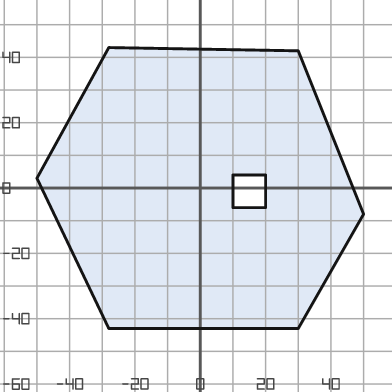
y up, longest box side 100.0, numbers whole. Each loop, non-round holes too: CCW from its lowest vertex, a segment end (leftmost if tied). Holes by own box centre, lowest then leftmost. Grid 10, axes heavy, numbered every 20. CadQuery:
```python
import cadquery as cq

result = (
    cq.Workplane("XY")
    .moveTo(-28.0, -43.0)
    .lineTo(30.0, -43.0)
    .lineTo(50.0, -8.0)
    .lineTo(30.0, 42.0)
    .lineTo(-28.0, 43.0)
    .lineTo(-50.0, 3.0)
    .close()
    .moveTo(10.0, -6.0)
    .lineTo(20.0, -6.0)
    .lineTo(20.0, 4.0)
    .lineTo(10.0, 4.0)
    .close()
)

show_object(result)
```